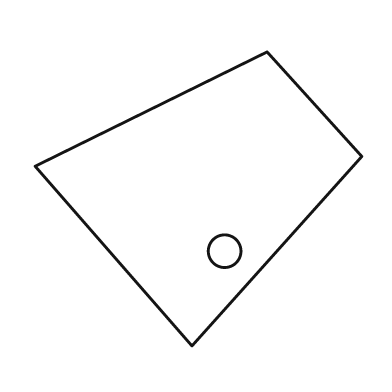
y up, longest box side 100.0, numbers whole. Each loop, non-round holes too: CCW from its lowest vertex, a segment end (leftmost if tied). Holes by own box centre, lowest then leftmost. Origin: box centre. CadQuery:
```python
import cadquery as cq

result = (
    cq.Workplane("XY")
    .moveTo(-2.0, -45.0)
    .lineTo(50.0, 13.0)
    .lineTo(21.0, 45.0)
    .lineTo(-50.0, 10.0)
    .close()
    .moveTo(8.0, -16.0)
    .circle(5.0)
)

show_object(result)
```